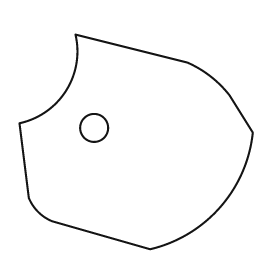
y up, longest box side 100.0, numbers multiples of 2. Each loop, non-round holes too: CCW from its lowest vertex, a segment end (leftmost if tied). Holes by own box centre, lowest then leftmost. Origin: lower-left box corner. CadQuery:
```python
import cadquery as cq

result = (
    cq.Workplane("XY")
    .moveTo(56.0, 0.0)
    .threePointArc((86.0, 18.0), (100.0, 50.0))
    .lineTo(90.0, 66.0)
    .threePointArc((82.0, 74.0), (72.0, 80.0))
    .lineTo(24.0, 92.0)
    .threePointArc((20.0, 68.0), (0.0, 54.0))
    .lineTo(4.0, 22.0)
    .threePointArc((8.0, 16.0), (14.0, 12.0))
    .close()
    .moveTo(32.0, 52.0)
    .circle(6.0)
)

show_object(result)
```